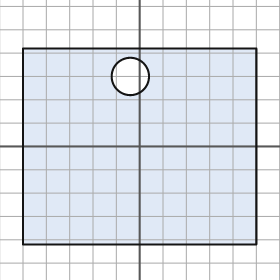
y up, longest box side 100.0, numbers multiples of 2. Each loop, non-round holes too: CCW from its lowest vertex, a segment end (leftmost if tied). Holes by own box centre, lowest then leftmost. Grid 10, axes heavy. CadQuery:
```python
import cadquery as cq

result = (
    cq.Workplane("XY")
    .moveTo(-50.0, -42.0)
    .lineTo(50.0, -42.0)
    .lineTo(50.0, 42.0)
    .lineTo(-50.0, 42.0)
    .close()
    .moveTo(-4.0, 30.0)
    .circle(8.0)
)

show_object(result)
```